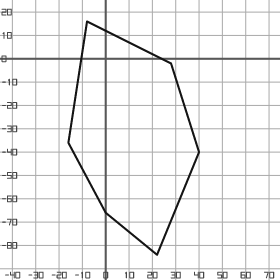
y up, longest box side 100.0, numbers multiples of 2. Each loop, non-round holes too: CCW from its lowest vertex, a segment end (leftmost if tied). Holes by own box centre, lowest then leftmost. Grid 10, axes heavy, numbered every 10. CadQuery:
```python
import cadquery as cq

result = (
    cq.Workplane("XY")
    .moveTo(22.0, -84.0)
    .lineTo(40.0, -40.0)
    .lineTo(28.0, -2.0)
    .lineTo(-8.0, 16.0)
    .lineTo(-16.0, -36.0)
    .lineTo(0.0, -66.0)
    .close()
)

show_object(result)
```